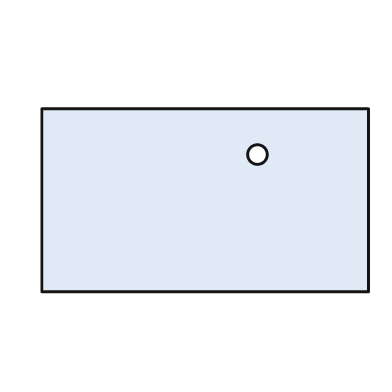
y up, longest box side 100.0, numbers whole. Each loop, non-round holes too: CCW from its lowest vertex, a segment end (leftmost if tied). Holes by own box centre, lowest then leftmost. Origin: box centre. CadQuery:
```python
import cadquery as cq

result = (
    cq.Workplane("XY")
    .moveTo(-50.0, -28.0)
    .lineTo(50.0, -28.0)
    .lineTo(50.0, 28.0)
    .lineTo(-50.0, 28.0)
    .close()
    .moveTo(16.0, 14.0)
    .circle(3.0)
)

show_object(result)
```